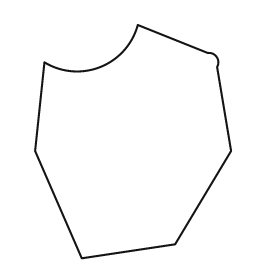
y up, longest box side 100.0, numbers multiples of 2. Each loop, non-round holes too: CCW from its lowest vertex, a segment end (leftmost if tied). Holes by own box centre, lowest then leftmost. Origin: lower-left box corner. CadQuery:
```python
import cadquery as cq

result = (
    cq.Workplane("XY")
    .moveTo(20.0, 0.0)
    .lineTo(60.0, 6.0)
    .lineTo(84.0, 46.0)
    .lineTo(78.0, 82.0)
    .threePointArc((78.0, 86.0), (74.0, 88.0))
    .lineTo(44.0, 100.0)
    .threePointArc((28.0, 82.0), (4.0, 84.0))
    .lineTo(0.0, 46.0)
    .close()
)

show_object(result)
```